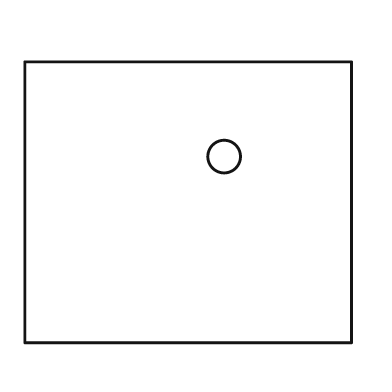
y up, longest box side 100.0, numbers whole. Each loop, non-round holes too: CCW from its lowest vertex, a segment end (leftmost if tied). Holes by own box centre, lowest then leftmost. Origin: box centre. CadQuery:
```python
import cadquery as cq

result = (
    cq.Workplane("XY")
    .moveTo(-50.0, -43.0)
    .lineTo(50.0, -43.0)
    .lineTo(50.0, 43.0)
    .lineTo(-50.0, 43.0)
    .close()
    .moveTo(11.0, 14.0)
    .circle(5.0)
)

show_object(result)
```